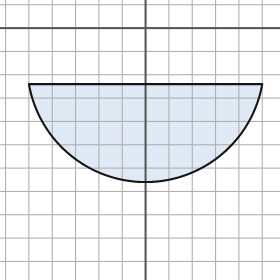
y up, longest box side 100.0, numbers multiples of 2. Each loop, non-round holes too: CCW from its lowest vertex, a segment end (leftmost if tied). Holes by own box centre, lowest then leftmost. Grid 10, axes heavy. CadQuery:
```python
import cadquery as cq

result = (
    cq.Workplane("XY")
    .moveTo(-50.0, -24.0)
    .threePointArc((0.0, -66.0), (50.0, -24.0))
    .close()
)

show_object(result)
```